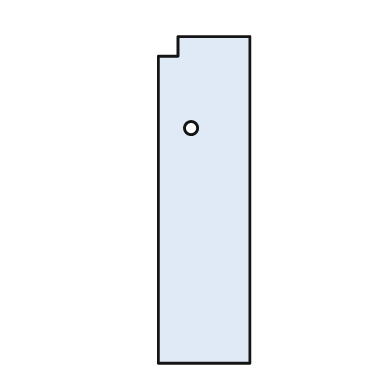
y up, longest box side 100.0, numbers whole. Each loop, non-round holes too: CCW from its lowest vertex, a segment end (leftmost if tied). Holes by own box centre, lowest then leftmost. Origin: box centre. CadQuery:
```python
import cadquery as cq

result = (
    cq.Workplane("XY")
    .moveTo(-14.0, -50.0)
    .lineTo(14.0, -50.0)
    .lineTo(14.0, 50.0)
    .lineTo(-8.0, 50.0)
    .lineTo(-8.0, 44.0)
    .lineTo(-14.0, 44.0)
    .close()
    .moveTo(-4.0, 22.0)
    .circle(2.0)
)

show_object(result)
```